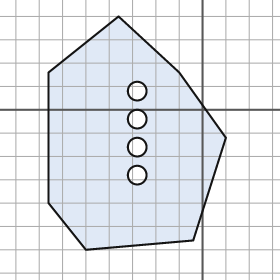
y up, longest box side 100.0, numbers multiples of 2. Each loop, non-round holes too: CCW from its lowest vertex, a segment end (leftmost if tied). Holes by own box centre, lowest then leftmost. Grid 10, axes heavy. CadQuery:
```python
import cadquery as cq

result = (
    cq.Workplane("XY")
    .moveTo(-50.0, -60.0)
    .lineTo(-4.0, -56.0)
    .lineTo(10.0, -12.0)
    .lineTo(-10.0, 16.0)
    .lineTo(-36.0, 40.0)
    .lineTo(-66.0, 16.0)
    .lineTo(-66.0, -40.0)
    .close()
    .moveTo(-28.0, -28.0)
    .circle(4.0)
    .moveTo(-28.0, -16.0)
    .circle(4.0)
    .moveTo(-28.0, -4.0)
    .circle(4.0)
    .moveTo(-28.0, 8.0)
    .circle(4.0)
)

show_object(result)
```